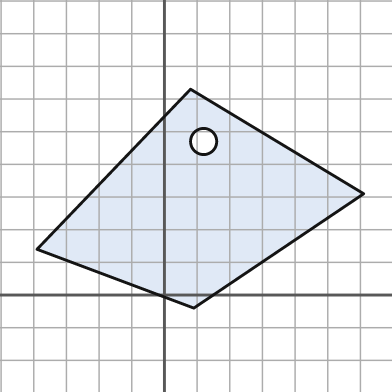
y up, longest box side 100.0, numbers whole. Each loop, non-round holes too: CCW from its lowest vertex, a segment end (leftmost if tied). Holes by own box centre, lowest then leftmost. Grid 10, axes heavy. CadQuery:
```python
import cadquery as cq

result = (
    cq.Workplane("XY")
    .moveTo(9.0, -4.0)
    .lineTo(61.0, 31.0)
    .lineTo(8.0, 63.0)
    .lineTo(-39.0, 14.0)
    .close()
    .moveTo(12.0, 47.0)
    .circle(4.0)
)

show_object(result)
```